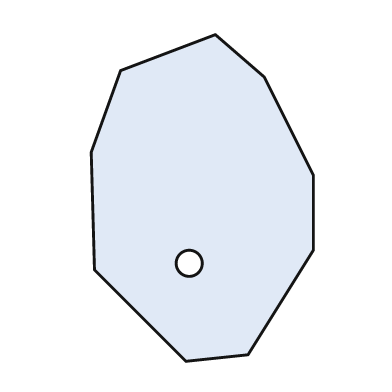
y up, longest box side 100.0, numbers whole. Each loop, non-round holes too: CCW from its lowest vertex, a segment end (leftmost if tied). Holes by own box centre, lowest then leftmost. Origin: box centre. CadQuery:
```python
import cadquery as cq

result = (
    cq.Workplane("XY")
    .moveTo(-5.0, -50.0)
    .lineTo(14.0, -48.0)
    .lineTo(34.0, -16.0)
    .lineTo(34.0, 7.0)
    .lineTo(19.0, 37.0)
    .lineTo(4.0, 50.0)
    .lineTo(-25.0, 39.0)
    .lineTo(-34.0, 14.0)
    .lineTo(-33.0, -22.0)
    .close()
    .moveTo(-4.0, -20.0)
    .circle(4.0)
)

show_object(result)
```